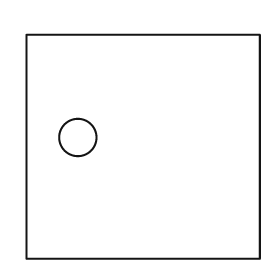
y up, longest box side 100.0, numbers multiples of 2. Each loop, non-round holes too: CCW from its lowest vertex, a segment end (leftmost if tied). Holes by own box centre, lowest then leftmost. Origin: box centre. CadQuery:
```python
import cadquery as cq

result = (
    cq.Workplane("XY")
    .moveTo(-50.0, -48.0)
    .lineTo(50.0, -48.0)
    .lineTo(50.0, 48.0)
    .lineTo(-50.0, 48.0)
    .close()
    .moveTo(-28.0, 4.0)
    .circle(8.0)
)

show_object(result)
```